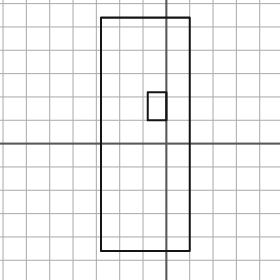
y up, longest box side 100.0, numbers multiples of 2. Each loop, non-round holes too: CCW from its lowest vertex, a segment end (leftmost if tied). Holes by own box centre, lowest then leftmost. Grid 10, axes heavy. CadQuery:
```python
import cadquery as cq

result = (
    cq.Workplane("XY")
    .moveTo(-28.0, -46.0)
    .lineTo(10.0, -46.0)
    .lineTo(10.0, 54.0)
    .lineTo(-28.0, 54.0)
    .close()
    .moveTo(-8.0, 10.0)
    .lineTo(0.0, 10.0)
    .lineTo(0.0, 22.0)
    .lineTo(-8.0, 22.0)
    .close()
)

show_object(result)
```